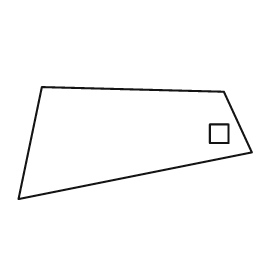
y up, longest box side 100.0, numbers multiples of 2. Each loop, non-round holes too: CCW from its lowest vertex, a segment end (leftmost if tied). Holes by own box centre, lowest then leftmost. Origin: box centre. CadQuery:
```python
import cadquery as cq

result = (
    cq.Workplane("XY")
    .moveTo(-50.0, -24.0)
    .lineTo(50.0, -4.0)
    .lineTo(38.0, 22.0)
    .lineTo(-40.0, 24.0)
    .close()
    .moveTo(32.0, 0.0)
    .lineTo(40.0, 0.0)
    .lineTo(40.0, 8.0)
    .lineTo(32.0, 8.0)
    .close()
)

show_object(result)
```